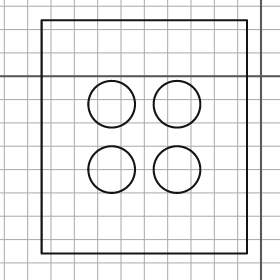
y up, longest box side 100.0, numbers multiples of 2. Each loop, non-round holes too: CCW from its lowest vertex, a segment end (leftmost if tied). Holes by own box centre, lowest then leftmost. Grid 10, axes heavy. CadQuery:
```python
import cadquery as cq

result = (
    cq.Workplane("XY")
    .moveTo(-94.0, -76.0)
    .lineTo(-6.0, -76.0)
    .lineTo(-6.0, 24.0)
    .lineTo(-94.0, 24.0)
    .close()
    .moveTo(-64.0, -40.0)
    .circle(10.0)
    .moveTo(-36.0, -40.0)
    .circle(10.0)
    .moveTo(-64.0, -12.0)
    .circle(10.0)
    .moveTo(-36.0, -12.0)
    .circle(10.0)
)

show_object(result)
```